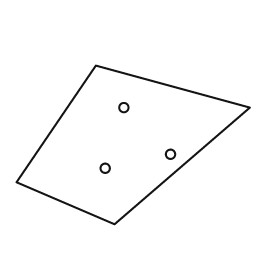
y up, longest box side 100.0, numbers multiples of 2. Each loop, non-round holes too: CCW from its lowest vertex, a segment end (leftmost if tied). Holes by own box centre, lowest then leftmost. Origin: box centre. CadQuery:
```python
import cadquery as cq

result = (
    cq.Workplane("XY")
    .moveTo(-8.0, -34.0)
    .lineTo(50.0, 16.0)
    .lineTo(-16.0, 34.0)
    .lineTo(-50.0, -16.0)
    .close()
    .moveTo(-12.0, -10.0)
    .circle(2.0)
    .moveTo(16.0, -4.0)
    .circle(2.0)
    .moveTo(-4.0, 16.0)
    .circle(2.0)
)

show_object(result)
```